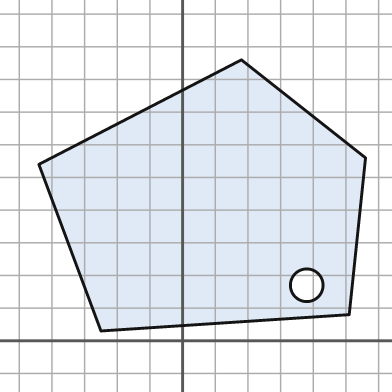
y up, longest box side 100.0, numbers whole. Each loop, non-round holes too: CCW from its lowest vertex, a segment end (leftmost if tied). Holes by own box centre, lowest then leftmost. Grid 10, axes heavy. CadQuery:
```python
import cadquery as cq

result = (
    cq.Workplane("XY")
    .moveTo(-25.0, 3.0)
    .lineTo(51.0, 8.0)
    .lineTo(56.0, 56.0)
    .lineTo(18.0, 86.0)
    .lineTo(-44.0, 54.0)
    .close()
    .moveTo(38.0, 17.0)
    .circle(5.0)
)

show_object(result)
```